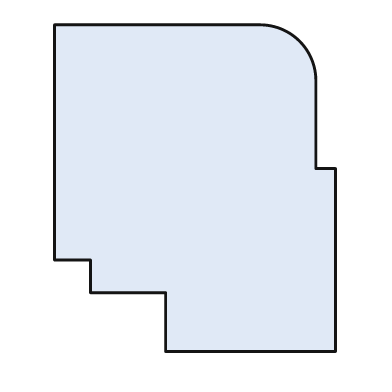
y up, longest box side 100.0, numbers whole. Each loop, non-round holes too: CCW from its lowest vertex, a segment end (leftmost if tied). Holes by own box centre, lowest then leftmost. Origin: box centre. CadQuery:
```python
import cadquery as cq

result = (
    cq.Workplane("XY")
    .moveTo(-9.0, -50.0)
    .lineTo(43.0, -50.0)
    .lineTo(43.0, 6.0)
    .lineTo(37.0, 6.0)
    .lineTo(37.0, 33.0)
    .threePointArc((32.0, 45.0), (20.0, 50.0))
    .lineTo(-43.0, 50.0)
    .lineTo(-43.0, -22.0)
    .lineTo(-32.0, -22.0)
    .lineTo(-32.0, -32.0)
    .lineTo(-9.0, -32.0)
    .close()
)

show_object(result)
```